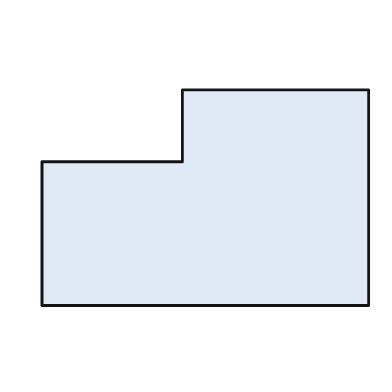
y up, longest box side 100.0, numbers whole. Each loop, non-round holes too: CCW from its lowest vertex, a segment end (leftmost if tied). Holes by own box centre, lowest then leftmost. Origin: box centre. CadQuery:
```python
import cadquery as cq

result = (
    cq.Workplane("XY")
    .moveTo(-50.0, -33.0)
    .lineTo(50.0, -33.0)
    .lineTo(50.0, 33.0)
    .lineTo(-7.0, 33.0)
    .lineTo(-7.0, 11.0)
    .lineTo(-50.0, 11.0)
    .close()
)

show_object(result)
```